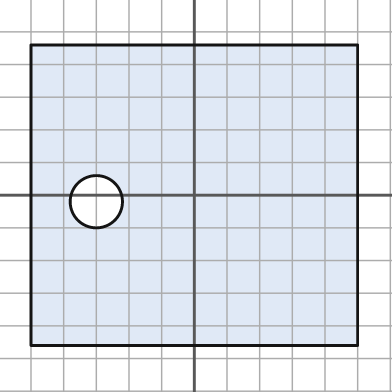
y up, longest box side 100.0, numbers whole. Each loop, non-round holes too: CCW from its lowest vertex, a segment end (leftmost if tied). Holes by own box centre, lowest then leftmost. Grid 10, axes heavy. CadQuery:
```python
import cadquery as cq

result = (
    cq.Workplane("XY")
    .moveTo(-50.0, -46.0)
    .lineTo(50.0, -46.0)
    .lineTo(50.0, 46.0)
    .lineTo(-50.0, 46.0)
    .close()
    .moveTo(-30.0, -2.0)
    .circle(8.0)
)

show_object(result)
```